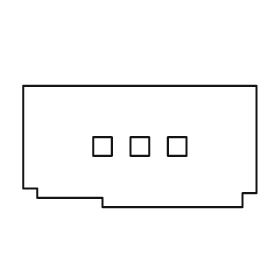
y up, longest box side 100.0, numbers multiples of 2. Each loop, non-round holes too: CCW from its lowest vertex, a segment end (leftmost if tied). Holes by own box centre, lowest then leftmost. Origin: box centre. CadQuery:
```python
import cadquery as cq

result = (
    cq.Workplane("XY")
    .moveTo(-16.0, -26.0)
    .lineTo(44.0, -26.0)
    .lineTo(44.0, -20.0)
    .lineTo(50.0, -20.0)
    .lineTo(50.0, 26.0)
    .lineTo(-50.0, 26.0)
    .lineTo(-50.0, -18.0)
    .lineTo(-44.0, -18.0)
    .lineTo(-44.0, -22.0)
    .lineTo(-16.0, -22.0)
    .close()
    .moveTo(-20.0, -4.0)
    .lineTo(-12.0, -4.0)
    .lineTo(-12.0, 4.0)
    .lineTo(-20.0, 4.0)
    .close()
    .moveTo(-4.0, -4.0)
    .lineTo(4.0, -4.0)
    .lineTo(4.0, 4.0)
    .lineTo(-4.0, 4.0)
    .close()
    .moveTo(12.0, -4.0)
    .lineTo(20.0, -4.0)
    .lineTo(20.0, 4.0)
    .lineTo(12.0, 4.0)
    .close()
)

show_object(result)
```